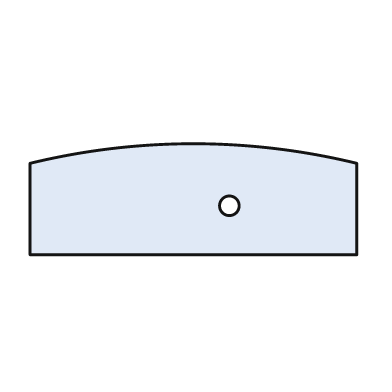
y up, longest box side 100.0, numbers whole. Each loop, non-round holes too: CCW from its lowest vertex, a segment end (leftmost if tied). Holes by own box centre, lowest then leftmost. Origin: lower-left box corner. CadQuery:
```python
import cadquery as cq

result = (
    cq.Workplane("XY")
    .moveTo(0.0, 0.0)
    .lineTo(100.0, 0.0)
    .lineTo(100.0, 28.0)
    .threePointArc((50.0, 34.0), (0.0, 28.0))
    .close()
    .moveTo(61.0, 15.0)
    .circle(3.0)
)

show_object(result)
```